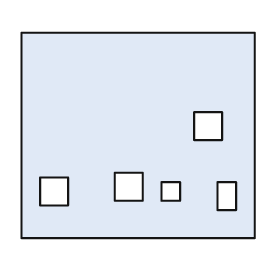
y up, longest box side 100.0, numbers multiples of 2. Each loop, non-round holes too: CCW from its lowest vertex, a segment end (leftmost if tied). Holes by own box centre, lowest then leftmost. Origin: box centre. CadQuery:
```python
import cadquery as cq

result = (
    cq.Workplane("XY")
    .moveTo(-50.0, -44.0)
    .lineTo(50.0, -44.0)
    .lineTo(50.0, 44.0)
    .lineTo(-50.0, 44.0)
    .close()
    .moveTo(34.0, -32.0)
    .lineTo(42.0, -32.0)
    .lineTo(42.0, -20.0)
    .lineTo(34.0, -20.0)
    .close()
    .moveTo(-42.0, -30.0)
    .lineTo(-30.0, -30.0)
    .lineTo(-30.0, -18.0)
    .lineTo(-42.0, -18.0)
    .close()
    .moveTo(10.0, -28.0)
    .lineTo(18.0, -28.0)
    .lineTo(18.0, -20.0)
    .lineTo(10.0, -20.0)
    .close()
    .moveTo(-10.0, -28.0)
    .lineTo(2.0, -28.0)
    .lineTo(2.0, -16.0)
    .lineTo(-10.0, -16.0)
    .close()
    .moveTo(24.0, -2.0)
    .lineTo(36.0, -2.0)
    .lineTo(36.0, 10.0)
    .lineTo(24.0, 10.0)
    .close()
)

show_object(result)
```